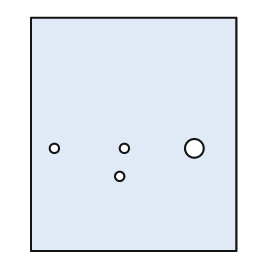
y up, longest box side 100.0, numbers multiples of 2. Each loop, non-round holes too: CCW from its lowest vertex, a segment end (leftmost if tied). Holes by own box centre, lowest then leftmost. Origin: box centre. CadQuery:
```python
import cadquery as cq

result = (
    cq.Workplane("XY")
    .moveTo(-44.0, -50.0)
    .lineTo(44.0, -50.0)
    .lineTo(44.0, 50.0)
    .lineTo(-44.0, 50.0)
    .close()
    .moveTo(-6.0, -18.0)
    .circle(2.0)
    .moveTo(-34.0, -6.0)
    .circle(2.0)
    .moveTo(-4.0, -6.0)
    .circle(2.0)
    .moveTo(26.0, -6.0)
    .circle(4.0)
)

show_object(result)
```